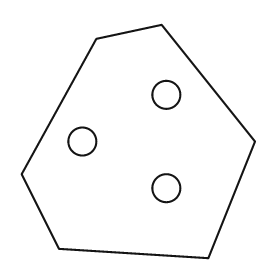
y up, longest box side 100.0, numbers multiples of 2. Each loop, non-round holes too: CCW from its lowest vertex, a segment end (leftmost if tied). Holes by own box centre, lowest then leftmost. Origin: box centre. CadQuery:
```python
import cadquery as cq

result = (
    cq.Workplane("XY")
    .moveTo(30.0, -50.0)
    .lineTo(50.0, 0.0)
    .lineTo(10.0, 50.0)
    .lineTo(-18.0, 44.0)
    .lineTo(-50.0, -14.0)
    .lineTo(-34.0, -46.0)
    .close()
    .moveTo(12.0, -20.0)
    .circle(6.0)
    .moveTo(-24.0, 0.0)
    .circle(6.0)
    .moveTo(12.0, 20.0)
    .circle(6.0)
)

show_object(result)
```